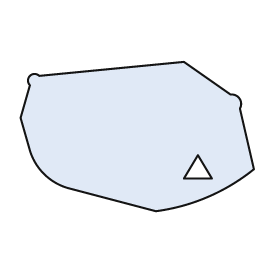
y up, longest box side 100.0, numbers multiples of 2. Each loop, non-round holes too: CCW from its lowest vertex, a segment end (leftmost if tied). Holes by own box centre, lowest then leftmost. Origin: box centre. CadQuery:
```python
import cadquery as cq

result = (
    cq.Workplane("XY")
    .moveTo(8.0, -32.0)
    .threePointArc((30.0, -26.0), (50.0, -14.0))
    .lineTo(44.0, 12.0)
    .threePointArc((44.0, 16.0), (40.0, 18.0))
    .lineTo(20.0, 32.0)
    .lineTo(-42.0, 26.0)
    .threePointArc((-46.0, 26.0), (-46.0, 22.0))
    .lineTo(-50.0, 8.0)
    .lineTo(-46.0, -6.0)
    .threePointArc((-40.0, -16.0), (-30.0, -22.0))
    .close()
    .moveTo(20.0, -18.0)
    .lineTo(32.0, -18.0)
    .lineTo(26.0, -8.0)
    .close()
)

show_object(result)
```